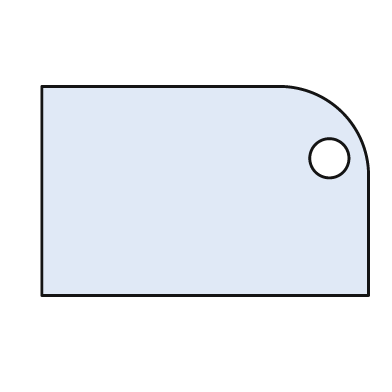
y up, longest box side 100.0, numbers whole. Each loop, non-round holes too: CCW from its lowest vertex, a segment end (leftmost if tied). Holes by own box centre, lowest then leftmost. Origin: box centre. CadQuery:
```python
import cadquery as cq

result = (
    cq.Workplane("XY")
    .moveTo(-50.0, -32.0)
    .lineTo(50.0, -32.0)
    .lineTo(50.0, 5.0)
    .threePointArc((42.0, 24.0), (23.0, 32.0))
    .lineTo(-50.0, 32.0)
    .close()
    .moveTo(38.0, 10.0)
    .circle(6.0)
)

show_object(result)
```